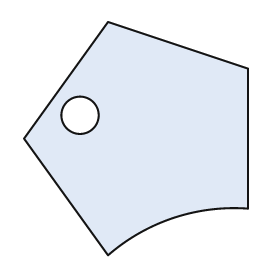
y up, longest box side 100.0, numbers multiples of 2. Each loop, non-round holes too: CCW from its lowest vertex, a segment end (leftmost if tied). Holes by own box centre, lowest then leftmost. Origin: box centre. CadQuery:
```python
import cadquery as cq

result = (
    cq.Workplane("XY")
    .moveTo(-12.0, -50.0)
    .threePointArc((16.0, -34.0), (48.0, -30.0))
    .lineTo(48.0, 30.0)
    .lineTo(-12.0, 50.0)
    .lineTo(-48.0, 0.0)
    .close()
    .moveTo(-24.0, 10.0)
    .circle(8.0)
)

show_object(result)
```